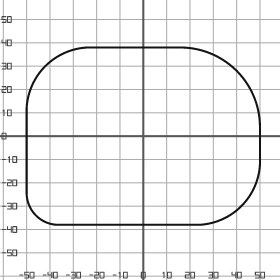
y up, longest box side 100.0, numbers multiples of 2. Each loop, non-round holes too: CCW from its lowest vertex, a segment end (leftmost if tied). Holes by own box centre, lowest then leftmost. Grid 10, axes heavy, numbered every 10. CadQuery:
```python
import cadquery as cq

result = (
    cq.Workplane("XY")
    .moveTo(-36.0, -38.0)
    .lineTo(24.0, -38.0)
    .threePointArc((42.0, -30.0), (50.0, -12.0))
    .lineTo(50.0, 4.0)
    .threePointArc((40.0, 28.0), (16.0, 38.0))
    .lineTo(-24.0, 38.0)
    .threePointArc((-42.0, 30.0), (-50.0, 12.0))
    .lineTo(-50.0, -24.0)
    .threePointArc((-46.0, -34.0), (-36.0, -38.0))
    .close()
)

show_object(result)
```